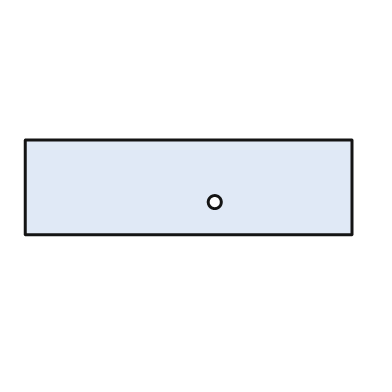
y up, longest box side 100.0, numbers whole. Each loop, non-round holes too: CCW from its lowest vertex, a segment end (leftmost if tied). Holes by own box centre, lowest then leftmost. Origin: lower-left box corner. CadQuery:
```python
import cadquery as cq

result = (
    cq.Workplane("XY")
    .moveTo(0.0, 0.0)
    .lineTo(100.0, 0.0)
    .lineTo(100.0, 29.0)
    .lineTo(0.0, 29.0)
    .close()
    .moveTo(58.0, 10.0)
    .circle(2.0)
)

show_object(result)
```